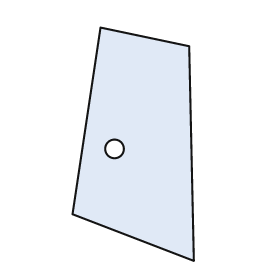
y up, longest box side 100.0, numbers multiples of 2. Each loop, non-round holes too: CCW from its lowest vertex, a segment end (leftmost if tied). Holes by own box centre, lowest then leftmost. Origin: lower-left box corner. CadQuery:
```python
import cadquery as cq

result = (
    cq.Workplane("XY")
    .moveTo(52.0, 0.0)
    .lineTo(50.0, 92.0)
    .lineTo(12.0, 100.0)
    .lineTo(0.0, 20.0)
    .close()
    .moveTo(18.0, 48.0)
    .circle(4.0)
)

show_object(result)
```